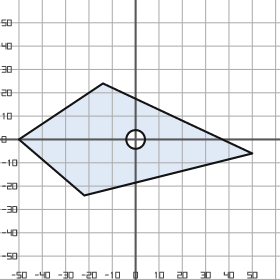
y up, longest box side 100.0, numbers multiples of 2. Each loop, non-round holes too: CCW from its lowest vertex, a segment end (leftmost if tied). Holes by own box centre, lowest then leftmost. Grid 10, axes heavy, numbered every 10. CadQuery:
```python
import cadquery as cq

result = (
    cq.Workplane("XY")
    .moveTo(-22.0, -24.0)
    .lineTo(50.0, -6.0)
    .lineTo(-14.0, 24.0)
    .lineTo(-50.0, 0.0)
    .close()
    .moveTo(0.0, 0.0)
    .circle(4.0)
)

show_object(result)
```